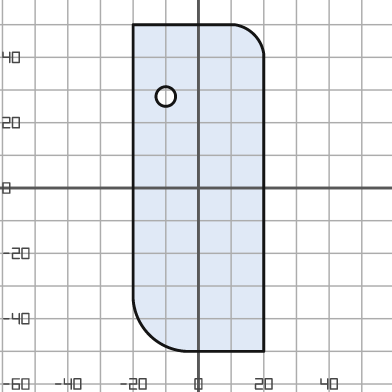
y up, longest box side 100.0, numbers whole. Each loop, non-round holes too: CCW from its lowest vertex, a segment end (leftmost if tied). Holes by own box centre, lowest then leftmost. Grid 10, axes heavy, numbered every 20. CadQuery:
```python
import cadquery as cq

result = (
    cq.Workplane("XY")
    .moveTo(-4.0, -50.0)
    .lineTo(20.0, -50.0)
    .lineTo(20.0, 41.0)
    .threePointArc((17.0, 47.0), (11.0, 50.0))
    .lineTo(-20.0, 50.0)
    .lineTo(-20.0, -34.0)
    .threePointArc((-15.0, -45.0), (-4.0, -50.0))
    .close()
    .moveTo(-10.0, 28.0)
    .circle(3.0)
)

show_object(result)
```